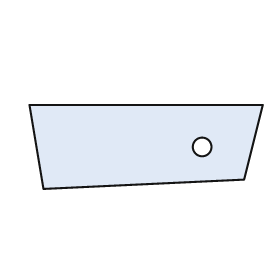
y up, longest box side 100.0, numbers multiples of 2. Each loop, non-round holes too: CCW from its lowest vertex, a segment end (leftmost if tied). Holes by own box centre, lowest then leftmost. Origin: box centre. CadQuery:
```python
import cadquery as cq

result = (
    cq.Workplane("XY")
    .moveTo(-44.0, -18.0)
    .lineTo(42.0, -14.0)
    .lineTo(50.0, 18.0)
    .lineTo(-50.0, 18.0)
    .close()
    .moveTo(24.0, 0.0)
    .circle(4.0)
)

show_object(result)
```